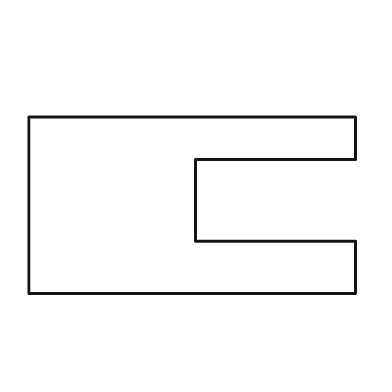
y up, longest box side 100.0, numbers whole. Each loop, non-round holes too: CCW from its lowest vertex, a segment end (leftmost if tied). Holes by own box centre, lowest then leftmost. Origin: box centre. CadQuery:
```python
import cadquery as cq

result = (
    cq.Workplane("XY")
    .moveTo(-50.0, -27.0)
    .lineTo(50.0, -27.0)
    .lineTo(50.0, -11.0)
    .lineTo(1.0, -11.0)
    .lineTo(1.0, 14.0)
    .lineTo(50.0, 14.0)
    .lineTo(50.0, 27.0)
    .lineTo(-50.0, 27.0)
    .close()
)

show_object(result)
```